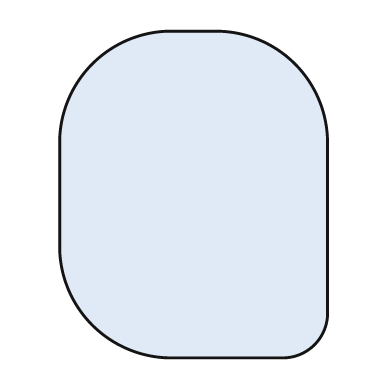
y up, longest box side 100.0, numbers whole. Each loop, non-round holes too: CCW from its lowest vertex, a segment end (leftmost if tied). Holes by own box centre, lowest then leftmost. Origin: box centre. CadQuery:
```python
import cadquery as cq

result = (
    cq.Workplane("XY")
    .moveTo(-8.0, -50.0)
    .lineTo(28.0, -50.0)
    .threePointArc((37.0, -46.0), (41.0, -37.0))
    .lineTo(41.0, 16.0)
    .threePointArc((31.0, 40.0), (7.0, 50.0))
    .lineTo(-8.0, 50.0)
    .threePointArc((-31.0, 40.0), (-41.0, 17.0))
    .lineTo(-41.0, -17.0)
    .threePointArc((-31.0, -40.0), (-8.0, -50.0))
    .close()
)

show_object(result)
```